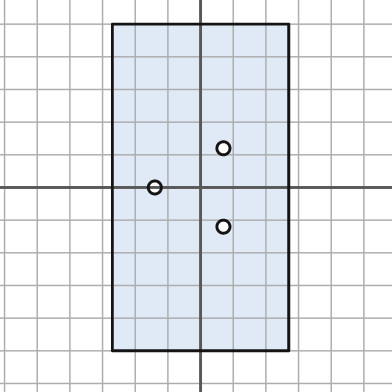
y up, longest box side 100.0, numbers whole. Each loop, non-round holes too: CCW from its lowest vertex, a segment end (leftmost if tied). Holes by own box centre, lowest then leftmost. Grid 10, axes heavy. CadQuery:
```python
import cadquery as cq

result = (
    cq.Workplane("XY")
    .moveTo(-27.0, -50.0)
    .lineTo(27.0, -50.0)
    .lineTo(27.0, 50.0)
    .lineTo(-27.0, 50.0)
    .close()
    .moveTo(7.0, -12.0)
    .circle(2.0)
    .moveTo(-14.0, 0.0)
    .circle(2.0)
    .moveTo(7.0, 12.0)
    .circle(2.0)
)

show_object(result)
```